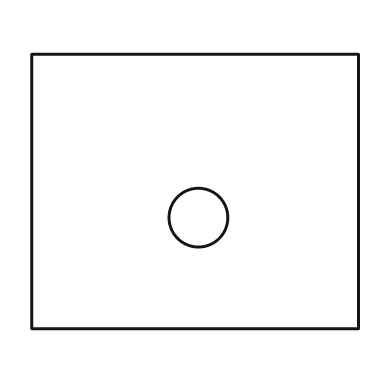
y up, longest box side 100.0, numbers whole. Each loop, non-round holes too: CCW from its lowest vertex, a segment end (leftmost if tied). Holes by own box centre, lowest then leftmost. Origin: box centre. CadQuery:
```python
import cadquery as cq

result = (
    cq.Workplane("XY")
    .moveTo(-50.0, -42.0)
    .lineTo(50.0, -42.0)
    .lineTo(50.0, 42.0)
    .lineTo(-50.0, 42.0)
    .close()
    .moveTo(1.0, -8.0)
    .circle(9.0)
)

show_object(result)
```